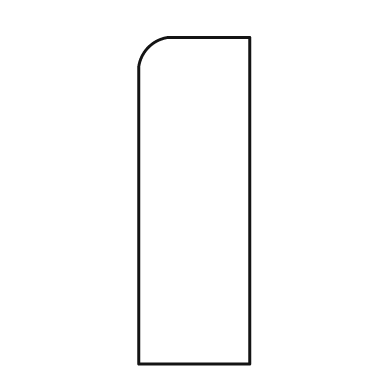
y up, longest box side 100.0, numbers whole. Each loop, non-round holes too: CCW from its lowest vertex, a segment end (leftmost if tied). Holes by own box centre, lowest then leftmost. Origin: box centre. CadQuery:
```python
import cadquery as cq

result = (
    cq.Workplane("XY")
    .moveTo(-17.0, -50.0)
    .lineTo(17.0, -50.0)
    .lineTo(17.0, 50.0)
    .lineTo(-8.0, 50.0)
    .threePointArc((-14.0, 47.0), (-17.0, 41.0))
    .close()
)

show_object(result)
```